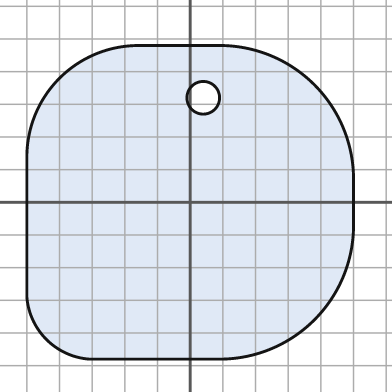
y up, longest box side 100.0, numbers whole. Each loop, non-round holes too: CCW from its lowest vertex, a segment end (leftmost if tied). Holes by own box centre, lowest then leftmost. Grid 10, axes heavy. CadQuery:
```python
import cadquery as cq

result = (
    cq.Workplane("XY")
    .moveTo(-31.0, -48.0)
    .lineTo(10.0, -48.0)
    .threePointArc((38.0, -36.0), (50.0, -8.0))
    .lineTo(50.0, 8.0)
    .threePointArc((38.0, 36.0), (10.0, 48.0))
    .lineTo(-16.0, 48.0)
    .threePointArc((-40.0, 38.0), (-50.0, 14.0))
    .lineTo(-50.0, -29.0)
    .threePointArc((-44.0, -42.0), (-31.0, -48.0))
    .close()
    .moveTo(4.0, 32.0)
    .circle(5.0)
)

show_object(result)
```